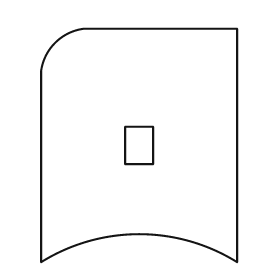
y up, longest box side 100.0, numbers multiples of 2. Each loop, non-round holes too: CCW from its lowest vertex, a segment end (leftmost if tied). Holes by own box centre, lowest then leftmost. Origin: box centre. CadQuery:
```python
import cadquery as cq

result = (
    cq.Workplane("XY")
    .moveTo(-42.0, -50.0)
    .threePointArc((0.0, -38.0), (42.0, -50.0))
    .lineTo(42.0, 50.0)
    .lineTo(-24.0, 50.0)
    .threePointArc((-36.0, 44.0), (-42.0, 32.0))
    .close()
    .moveTo(-6.0, -8.0)
    .lineTo(6.0, -8.0)
    .lineTo(6.0, 8.0)
    .lineTo(-6.0, 8.0)
    .close()
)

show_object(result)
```